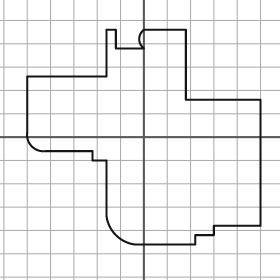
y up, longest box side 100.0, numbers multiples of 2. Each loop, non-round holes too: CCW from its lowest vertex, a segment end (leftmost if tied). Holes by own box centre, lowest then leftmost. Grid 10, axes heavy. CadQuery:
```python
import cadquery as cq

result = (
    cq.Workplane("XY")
    .moveTo(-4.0, -46.0)
    .lineTo(22.0, -46.0)
    .lineTo(22.0, -42.0)
    .lineTo(30.0, -42.0)
    .lineTo(30.0, -38.0)
    .lineTo(50.0, -38.0)
    .lineTo(50.0, 16.0)
    .lineTo(18.0, 16.0)
    .lineTo(18.0, 46.0)
    .lineTo(0.0, 46.0)
    .threePointArc((-2.0, 42.0), (0.0, 38.0))
    .lineTo(-12.0, 38.0)
    .lineTo(-12.0, 46.0)
    .lineTo(-16.0, 46.0)
    .lineTo(-16.0, 26.0)
    .lineTo(-50.0, 26.0)
    .lineTo(-50.0, 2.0)
    .threePointArc((-48.0, -4.0), (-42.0, -6.0))
    .lineTo(-22.0, -6.0)
    .lineTo(-22.0, -10.0)
    .lineTo(-16.0, -10.0)
    .lineTo(-16.0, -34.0)
    .threePointArc((-12.0, -42.0), (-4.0, -46.0))
    .close()
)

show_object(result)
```